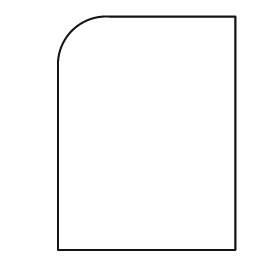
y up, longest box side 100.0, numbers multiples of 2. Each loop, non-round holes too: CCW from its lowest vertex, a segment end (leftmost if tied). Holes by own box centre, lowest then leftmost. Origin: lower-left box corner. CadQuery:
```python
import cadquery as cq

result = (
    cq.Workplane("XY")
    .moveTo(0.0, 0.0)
    .lineTo(76.0, 0.0)
    .lineTo(76.0, 100.0)
    .lineTo(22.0, 100.0)
    .threePointArc((6.0, 94.0), (0.0, 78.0))
    .close()
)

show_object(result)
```